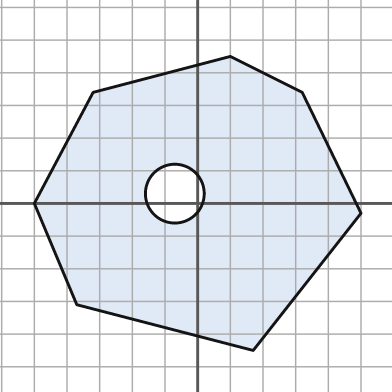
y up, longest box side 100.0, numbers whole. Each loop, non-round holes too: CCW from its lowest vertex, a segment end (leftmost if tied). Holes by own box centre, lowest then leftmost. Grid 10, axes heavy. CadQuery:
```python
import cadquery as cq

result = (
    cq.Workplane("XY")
    .moveTo(17.0, -45.0)
    .lineTo(50.0, -3.0)
    .lineTo(32.0, 34.0)
    .lineTo(10.0, 45.0)
    .lineTo(-32.0, 34.0)
    .lineTo(-50.0, 0.0)
    .lineTo(-37.0, -31.0)
    .close()
    .moveTo(-7.0, 3.0)
    .circle(9.0)
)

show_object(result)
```